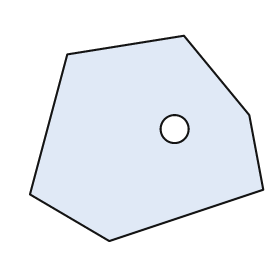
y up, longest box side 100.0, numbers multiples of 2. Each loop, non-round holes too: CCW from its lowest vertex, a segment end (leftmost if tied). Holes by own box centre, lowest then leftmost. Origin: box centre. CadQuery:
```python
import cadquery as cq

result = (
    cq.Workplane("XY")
    .moveTo(-16.0, -44.0)
    .lineTo(50.0, -22.0)
    .lineTo(44.0, 10.0)
    .lineTo(16.0, 44.0)
    .lineTo(-34.0, 36.0)
    .lineTo(-50.0, -24.0)
    .close()
    .moveTo(12.0, 4.0)
    .circle(6.0)
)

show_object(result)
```